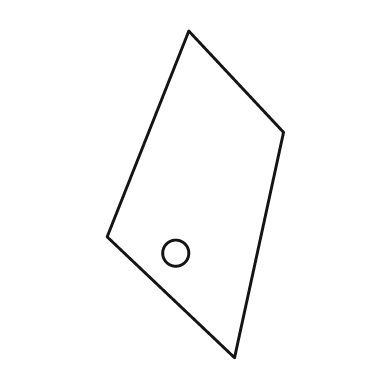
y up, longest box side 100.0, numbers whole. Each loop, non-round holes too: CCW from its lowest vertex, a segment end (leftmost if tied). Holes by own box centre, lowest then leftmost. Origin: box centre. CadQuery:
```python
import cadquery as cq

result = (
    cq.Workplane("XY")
    .moveTo(12.0, -50.0)
    .lineTo(27.0, 19.0)
    .lineTo(-2.0, 50.0)
    .lineTo(-27.0, -13.0)
    .close()
    .moveTo(-6.0, -18.0)
    .circle(4.0)
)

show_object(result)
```